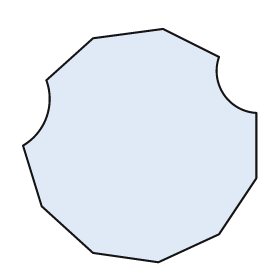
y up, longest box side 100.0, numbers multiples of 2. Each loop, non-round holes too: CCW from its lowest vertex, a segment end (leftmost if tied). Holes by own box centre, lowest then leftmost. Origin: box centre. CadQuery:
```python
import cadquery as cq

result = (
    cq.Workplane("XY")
    .moveTo(8.0, -50.0)
    .lineTo(34.0, -38.0)
    .lineTo(50.0, -14.0)
    .lineTo(50.0, 14.0)
    .threePointArc((36.0, 22.0), (34.0, 38.0))
    .lineTo(10.0, 50.0)
    .lineTo(-20.0, 46.0)
    .lineTo(-40.0, 28.0)
    .threePointArc((-40.0, 12.0), (-50.0, 0.0))
    .lineTo(-42.0, -26.0)
    .lineTo(-20.0, -46.0)
    .close()
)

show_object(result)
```